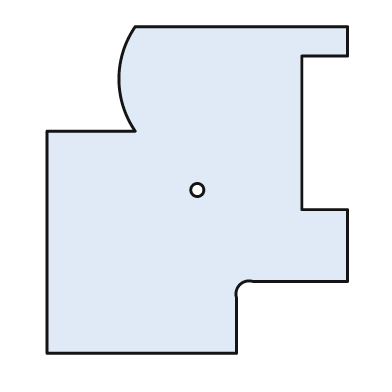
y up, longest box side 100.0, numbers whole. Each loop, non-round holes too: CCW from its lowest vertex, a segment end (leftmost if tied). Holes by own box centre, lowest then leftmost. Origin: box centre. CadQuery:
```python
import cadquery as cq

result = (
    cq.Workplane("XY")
    .moveTo(-46.0, -50.0)
    .lineTo(12.0, -50.0)
    .lineTo(12.0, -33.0)
    .threePointArc((13.0, -29.0), (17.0, -28.0))
    .lineTo(46.0, -28.0)
    .lineTo(46.0, -6.0)
    .lineTo(32.0, -6.0)
    .lineTo(32.0, 41.0)
    .lineTo(46.0, 41.0)
    .lineTo(46.0, 50.0)
    .lineTo(-19.0, 50.0)
    .threePointArc((-24.0, 34.0), (-19.0, 18.0))
    .lineTo(-46.0, 18.0)
    .close()
    .moveTo(0.0, 0.0)
    .circle(2.0)
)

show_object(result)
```